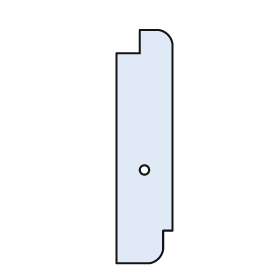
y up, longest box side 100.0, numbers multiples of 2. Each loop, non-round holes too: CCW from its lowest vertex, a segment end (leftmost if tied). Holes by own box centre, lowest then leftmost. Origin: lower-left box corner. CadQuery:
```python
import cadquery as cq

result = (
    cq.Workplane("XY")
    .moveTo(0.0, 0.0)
    .lineTo(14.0, 0.0)
    .threePointArc((18.0, 2.0), (20.0, 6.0))
    .lineTo(20.0, 14.0)
    .lineTo(24.0, 14.0)
    .lineTo(24.0, 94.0)
    .threePointArc((22.0, 98.0), (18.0, 100.0))
    .lineTo(10.0, 100.0)
    .lineTo(10.0, 90.0)
    .lineTo(0.0, 90.0)
    .close()
    .moveTo(12.0, 40.0)
    .circle(2.0)
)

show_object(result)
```